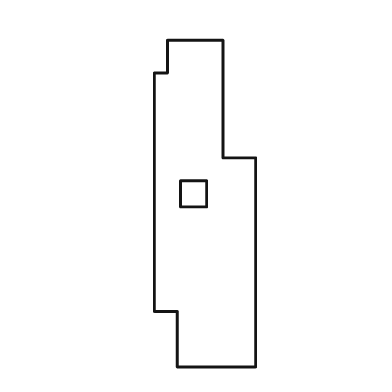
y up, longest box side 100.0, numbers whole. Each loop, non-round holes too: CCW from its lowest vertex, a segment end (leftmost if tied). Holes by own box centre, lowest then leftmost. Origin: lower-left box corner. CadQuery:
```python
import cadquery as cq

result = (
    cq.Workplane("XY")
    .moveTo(7.0, 0.0)
    .lineTo(31.0, 0.0)
    .lineTo(31.0, 64.0)
    .lineTo(21.0, 64.0)
    .lineTo(21.0, 100.0)
    .lineTo(4.0, 100.0)
    .lineTo(4.0, 90.0)
    .lineTo(0.0, 90.0)
    .lineTo(0.0, 17.0)
    .lineTo(7.0, 17.0)
    .close()
    .moveTo(8.0, 49.0)
    .lineTo(16.0, 49.0)
    .lineTo(16.0, 57.0)
    .lineTo(8.0, 57.0)
    .close()
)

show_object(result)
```